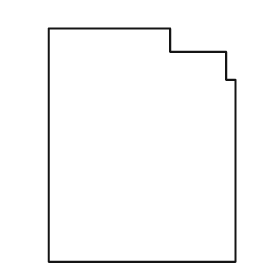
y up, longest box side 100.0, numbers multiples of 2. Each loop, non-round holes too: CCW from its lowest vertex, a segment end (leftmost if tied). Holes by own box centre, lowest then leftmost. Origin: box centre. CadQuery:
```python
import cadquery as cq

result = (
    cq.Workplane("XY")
    .moveTo(-40.0, -50.0)
    .lineTo(40.0, -50.0)
    .lineTo(40.0, 28.0)
    .lineTo(36.0, 28.0)
    .lineTo(36.0, 40.0)
    .lineTo(12.0, 40.0)
    .lineTo(12.0, 50.0)
    .lineTo(-40.0, 50.0)
    .close()
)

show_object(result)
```